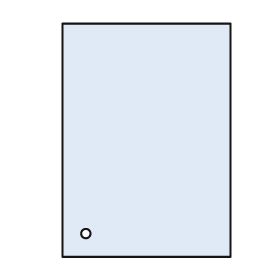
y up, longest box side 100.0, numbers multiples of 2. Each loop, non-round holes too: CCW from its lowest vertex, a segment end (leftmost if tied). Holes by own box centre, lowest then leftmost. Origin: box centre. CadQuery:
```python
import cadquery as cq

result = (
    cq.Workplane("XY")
    .moveTo(-36.0, -50.0)
    .lineTo(36.0, -50.0)
    .lineTo(36.0, 50.0)
    .lineTo(-36.0, 50.0)
    .close()
    .moveTo(-26.0, -40.0)
    .circle(2.0)
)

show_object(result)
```